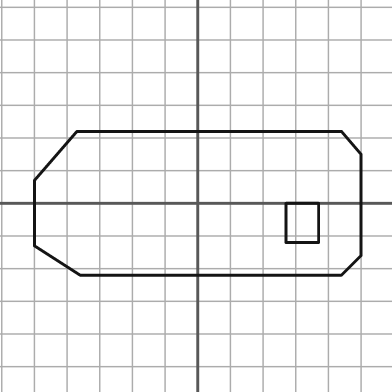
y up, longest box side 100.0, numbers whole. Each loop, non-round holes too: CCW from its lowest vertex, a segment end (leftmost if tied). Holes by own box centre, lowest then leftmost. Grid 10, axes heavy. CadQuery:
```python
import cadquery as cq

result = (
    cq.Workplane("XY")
    .moveTo(-36.0, -22.0)
    .lineTo(44.0, -22.0)
    .lineTo(50.0, -16.0)
    .lineTo(50.0, 15.0)
    .lineTo(44.0, 22.0)
    .lineTo(-37.0, 22.0)
    .lineTo(-50.0, 7.0)
    .lineTo(-50.0, -13.0)
    .close()
    .moveTo(27.0, -12.0)
    .lineTo(37.0, -12.0)
    .lineTo(37.0, 0.0)
    .lineTo(27.0, 0.0)
    .close()
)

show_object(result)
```